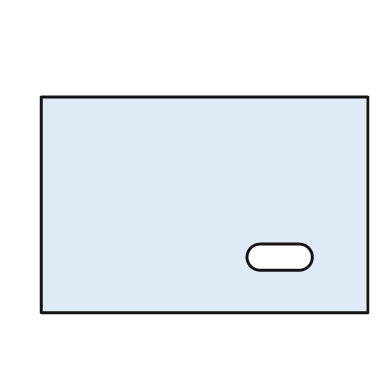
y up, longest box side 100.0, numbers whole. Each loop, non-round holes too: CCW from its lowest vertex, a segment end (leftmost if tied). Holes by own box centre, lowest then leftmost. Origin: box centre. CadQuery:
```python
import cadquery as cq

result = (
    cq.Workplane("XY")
    .moveTo(-50.0, -33.0)
    .lineTo(50.0, -33.0)
    .lineTo(50.0, 33.0)
    .lineTo(-50.0, 33.0)
    .close()
    .moveTo(17.0, -20.0)
    .lineTo(29.0, -20.0)
    .threePointArc((33.0, -16.0), (29.0, -12.0))
    .lineTo(17.0, -12.0)
    .threePointArc((13.0, -16.0), (17.0, -20.0))
    .close()
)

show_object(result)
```